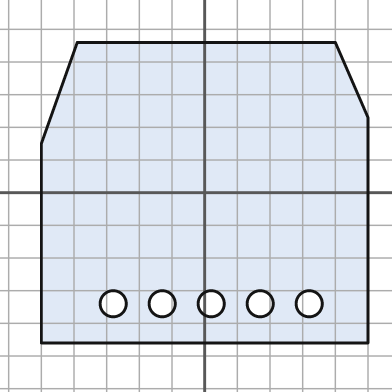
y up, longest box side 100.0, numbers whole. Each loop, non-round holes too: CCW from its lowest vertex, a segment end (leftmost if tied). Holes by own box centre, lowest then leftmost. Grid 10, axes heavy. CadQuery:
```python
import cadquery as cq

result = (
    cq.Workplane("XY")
    .moveTo(-50.0, -46.0)
    .lineTo(50.0, -46.0)
    .lineTo(50.0, 23.0)
    .lineTo(40.0, 46.0)
    .lineTo(-39.0, 46.0)
    .lineTo(-50.0, 15.0)
    .close()
    .moveTo(-28.0, -34.0)
    .circle(4.0)
    .moveTo(-13.0, -34.0)
    .circle(4.0)
    .moveTo(2.0, -34.0)
    .circle(4.0)
    .moveTo(17.0, -34.0)
    .circle(4.0)
    .moveTo(32.0, -34.0)
    .circle(4.0)
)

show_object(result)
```